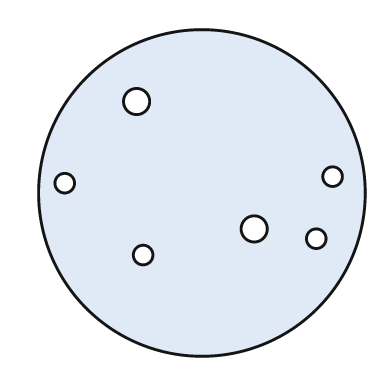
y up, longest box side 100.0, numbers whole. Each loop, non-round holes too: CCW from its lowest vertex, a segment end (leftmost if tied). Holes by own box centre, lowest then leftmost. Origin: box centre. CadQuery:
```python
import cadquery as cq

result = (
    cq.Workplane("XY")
    .moveTo(0.0, 0.0)
    .circle(50.0)
    .moveTo(-18.0, -19.0)
    .circle(3.0)
    .moveTo(35.0, -14.0)
    .circle(3.0)
    .moveTo(16.0, -11.0)
    .circle(4.0)
    .moveTo(-42.0, 3.0)
    .circle(3.0)
    .moveTo(40.0, 5.0)
    .circle(3.0)
    .moveTo(-20.0, 28.0)
    .circle(4.0)
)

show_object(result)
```